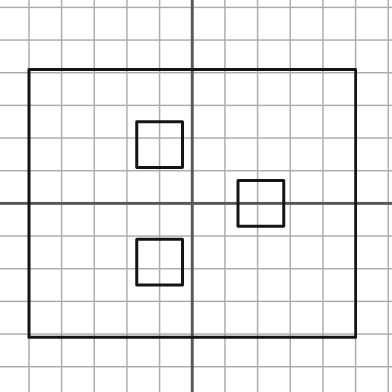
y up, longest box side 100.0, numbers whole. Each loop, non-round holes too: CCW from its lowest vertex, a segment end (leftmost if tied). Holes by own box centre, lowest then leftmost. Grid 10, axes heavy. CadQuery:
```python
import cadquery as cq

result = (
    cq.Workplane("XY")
    .moveTo(-50.0, -41.0)
    .lineTo(50.0, -41.0)
    .lineTo(50.0, 41.0)
    .lineTo(-50.0, 41.0)
    .close()
    .moveTo(-17.0, -25.0)
    .lineTo(-3.0, -25.0)
    .lineTo(-3.0, -11.0)
    .lineTo(-17.0, -11.0)
    .close()
    .moveTo(14.0, -7.0)
    .lineTo(28.0, -7.0)
    .lineTo(28.0, 7.0)
    .lineTo(14.0, 7.0)
    .close()
    .moveTo(-17.0, 11.0)
    .lineTo(-3.0, 11.0)
    .lineTo(-3.0, 25.0)
    .lineTo(-17.0, 25.0)
    .close()
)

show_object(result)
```